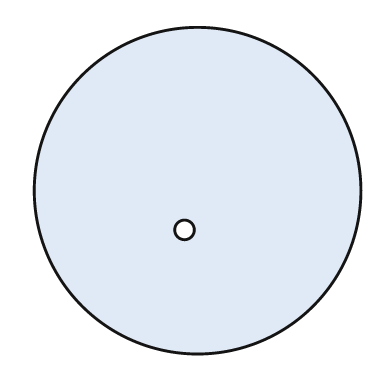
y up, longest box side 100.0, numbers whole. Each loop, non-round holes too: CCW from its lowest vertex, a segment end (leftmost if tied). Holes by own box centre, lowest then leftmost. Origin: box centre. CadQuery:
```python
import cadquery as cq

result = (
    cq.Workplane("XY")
    .moveTo(0.0, 0.0)
    .circle(50.0)
    .moveTo(-4.0, -12.0)
    .circle(3.0)
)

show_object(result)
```